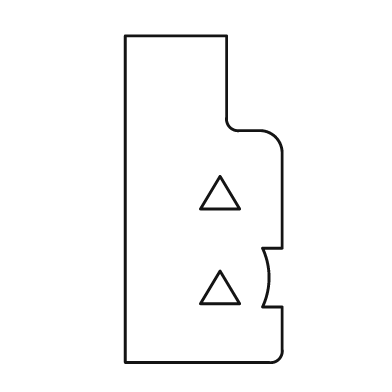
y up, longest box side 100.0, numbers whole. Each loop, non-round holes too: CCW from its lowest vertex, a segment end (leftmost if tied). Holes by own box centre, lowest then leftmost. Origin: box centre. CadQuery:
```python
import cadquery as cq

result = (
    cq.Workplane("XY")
    .moveTo(-24.0, -50.0)
    .lineTo(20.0, -50.0)
    .threePointArc((23.0, -49.0), (24.0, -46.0))
    .lineTo(24.0, -33.0)
    .lineTo(18.0, -33.0)
    .threePointArc((20.0, -24.0), (18.0, -15.0))
    .lineTo(24.0, -15.0)
    .lineTo(24.0, 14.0)
    .threePointArc((22.0, 19.0), (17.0, 21.0))
    .lineTo(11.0, 21.0)
    .threePointArc((8.0, 22.0), (7.0, 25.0))
    .lineTo(7.0, 50.0)
    .lineTo(-24.0, 50.0)
    .close()
    .moveTo(-1.0, -32.0)
    .lineTo(11.0, -32.0)
    .lineTo(5.0, -22.0)
    .close()
    .moveTo(-1.0, -3.0)
    .lineTo(11.0, -3.0)
    .lineTo(5.0, 7.0)
    .close()
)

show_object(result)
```